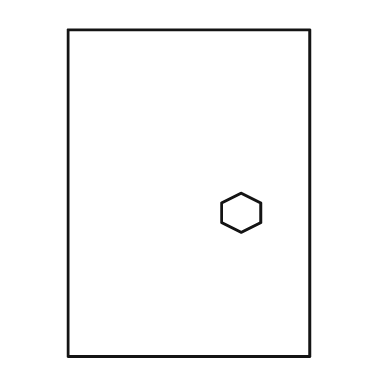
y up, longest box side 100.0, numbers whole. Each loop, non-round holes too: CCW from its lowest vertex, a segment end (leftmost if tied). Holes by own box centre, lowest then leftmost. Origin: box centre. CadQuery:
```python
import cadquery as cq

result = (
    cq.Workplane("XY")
    .moveTo(-37.0, -50.0)
    .lineTo(37.0, -50.0)
    .lineTo(37.0, 50.0)
    .lineTo(-37.0, 50.0)
    .close()
    .moveTo(16.0, -12.0)
    .lineTo(22.0, -9.0)
    .lineTo(22.0, -3.0)
    .lineTo(16.0, 0.0)
    .lineTo(10.0, -3.0)
    .lineTo(10.0, -9.0)
    .close()
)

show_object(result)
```